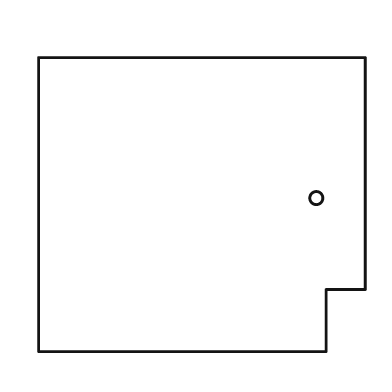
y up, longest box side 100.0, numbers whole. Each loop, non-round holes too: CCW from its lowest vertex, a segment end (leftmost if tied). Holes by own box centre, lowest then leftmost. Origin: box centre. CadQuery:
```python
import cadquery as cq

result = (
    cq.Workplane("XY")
    .moveTo(-50.0, -45.0)
    .lineTo(38.0, -45.0)
    .lineTo(38.0, -26.0)
    .lineTo(50.0, -26.0)
    .lineTo(50.0, 45.0)
    .lineTo(-50.0, 45.0)
    .close()
    .moveTo(35.0, 2.0)
    .circle(2.0)
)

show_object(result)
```